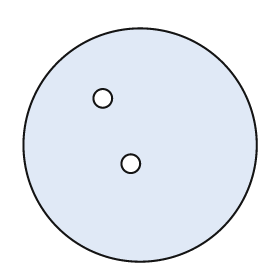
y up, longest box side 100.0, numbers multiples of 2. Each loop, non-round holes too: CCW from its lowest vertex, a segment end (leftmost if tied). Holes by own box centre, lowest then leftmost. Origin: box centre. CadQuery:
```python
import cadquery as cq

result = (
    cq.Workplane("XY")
    .moveTo(0.0, 0.0)
    .circle(50.0)
    .moveTo(-4.0, -8.0)
    .circle(4.0)
    .moveTo(-16.0, 20.0)
    .circle(4.0)
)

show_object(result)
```